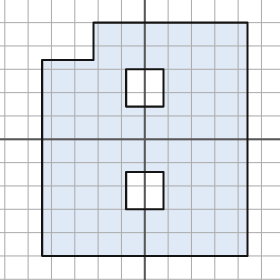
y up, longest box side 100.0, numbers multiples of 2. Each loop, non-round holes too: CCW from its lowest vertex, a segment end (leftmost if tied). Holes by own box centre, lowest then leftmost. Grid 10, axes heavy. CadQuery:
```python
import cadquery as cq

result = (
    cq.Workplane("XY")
    .moveTo(-44.0, -50.0)
    .lineTo(44.0, -50.0)
    .lineTo(44.0, 50.0)
    .lineTo(-22.0, 50.0)
    .lineTo(-22.0, 34.0)
    .lineTo(-44.0, 34.0)
    .close()
    .moveTo(-8.0, -30.0)
    .lineTo(8.0, -30.0)
    .lineTo(8.0, -14.0)
    .lineTo(-8.0, -14.0)
    .close()
    .moveTo(-8.0, 14.0)
    .lineTo(8.0, 14.0)
    .lineTo(8.0, 30.0)
    .lineTo(-8.0, 30.0)
    .close()
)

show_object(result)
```